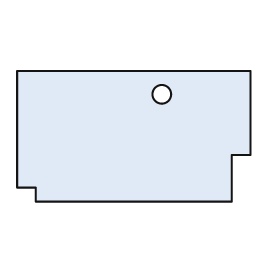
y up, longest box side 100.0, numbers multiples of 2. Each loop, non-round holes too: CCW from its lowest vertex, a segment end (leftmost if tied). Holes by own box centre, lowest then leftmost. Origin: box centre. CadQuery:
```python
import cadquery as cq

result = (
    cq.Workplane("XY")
    .moveTo(-42.0, -28.0)
    .lineTo(42.0, -28.0)
    .lineTo(42.0, -8.0)
    .lineTo(50.0, -8.0)
    .lineTo(50.0, 28.0)
    .lineTo(-50.0, 28.0)
    .lineTo(-50.0, -22.0)
    .lineTo(-42.0, -22.0)
    .close()
    .moveTo(12.0, 18.0)
    .circle(4.0)
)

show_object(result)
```